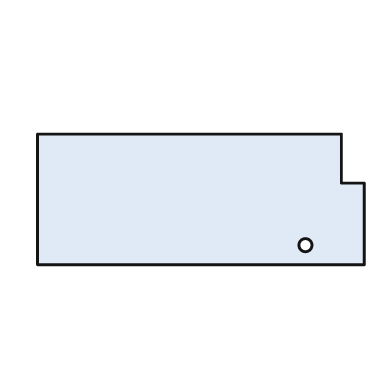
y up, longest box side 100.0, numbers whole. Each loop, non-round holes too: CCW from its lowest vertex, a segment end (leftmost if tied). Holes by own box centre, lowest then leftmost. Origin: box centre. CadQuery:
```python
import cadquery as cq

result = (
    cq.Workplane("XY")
    .moveTo(-50.0, -20.0)
    .lineTo(50.0, -20.0)
    .lineTo(50.0, 5.0)
    .lineTo(43.0, 5.0)
    .lineTo(43.0, 20.0)
    .lineTo(-50.0, 20.0)
    .close()
    .moveTo(32.0, -14.0)
    .circle(2.0)
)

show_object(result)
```